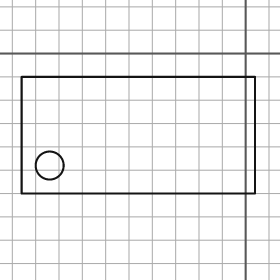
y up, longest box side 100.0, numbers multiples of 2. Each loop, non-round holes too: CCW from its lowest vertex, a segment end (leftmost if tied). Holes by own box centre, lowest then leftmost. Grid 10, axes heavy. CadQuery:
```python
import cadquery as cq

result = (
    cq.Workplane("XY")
    .moveTo(-96.0, -60.0)
    .lineTo(4.0, -60.0)
    .lineTo(4.0, -10.0)
    .lineTo(-96.0, -10.0)
    .close()
    .moveTo(-84.0, -48.0)
    .circle(6.0)
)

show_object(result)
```